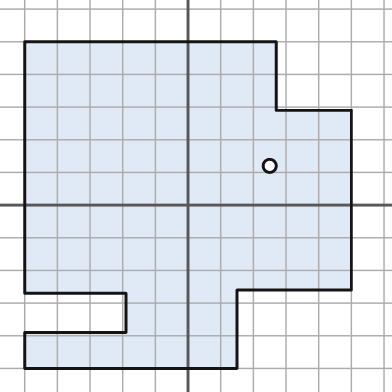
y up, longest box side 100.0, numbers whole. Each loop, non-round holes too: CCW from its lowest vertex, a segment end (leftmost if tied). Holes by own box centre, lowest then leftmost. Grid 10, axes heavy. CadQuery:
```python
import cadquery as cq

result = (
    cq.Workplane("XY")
    .moveTo(-50.0, -50.0)
    .lineTo(15.0, -50.0)
    .lineTo(15.0, -26.0)
    .lineTo(50.0, -26.0)
    .lineTo(50.0, 29.0)
    .lineTo(27.0, 29.0)
    .lineTo(27.0, 50.0)
    .lineTo(-50.0, 50.0)
    .lineTo(-50.0, -27.0)
    .lineTo(-19.0, -27.0)
    .lineTo(-19.0, -39.0)
    .lineTo(-50.0, -39.0)
    .close()
    .moveTo(25.0, 12.0)
    .circle(2.0)
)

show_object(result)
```